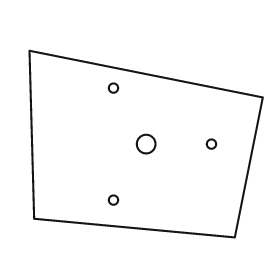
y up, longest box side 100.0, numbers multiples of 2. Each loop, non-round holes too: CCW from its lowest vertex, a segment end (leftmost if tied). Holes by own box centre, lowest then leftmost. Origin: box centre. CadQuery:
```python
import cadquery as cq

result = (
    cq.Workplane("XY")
    .moveTo(38.0, -40.0)
    .lineTo(50.0, 20.0)
    .lineTo(-50.0, 40.0)
    .lineTo(-48.0, -32.0)
    .close()
    .moveTo(-14.0, -24.0)
    .circle(2.0)
    .moveTo(0.0, 0.0)
    .circle(4.0)
    .moveTo(28.0, 0.0)
    .circle(2.0)
    .moveTo(-14.0, 24.0)
    .circle(2.0)
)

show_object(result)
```